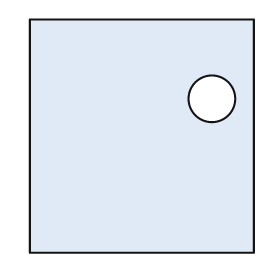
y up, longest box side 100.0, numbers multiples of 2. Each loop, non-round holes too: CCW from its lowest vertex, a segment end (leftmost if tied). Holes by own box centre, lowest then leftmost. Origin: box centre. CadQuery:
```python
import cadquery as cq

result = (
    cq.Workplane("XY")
    .moveTo(-48.0, -50.0)
    .lineTo(48.0, -50.0)
    .lineTo(48.0, 50.0)
    .lineTo(-48.0, 50.0)
    .close()
    .moveTo(30.0, 16.0)
    .circle(10.0)
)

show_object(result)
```